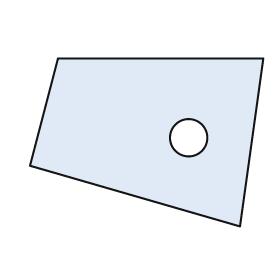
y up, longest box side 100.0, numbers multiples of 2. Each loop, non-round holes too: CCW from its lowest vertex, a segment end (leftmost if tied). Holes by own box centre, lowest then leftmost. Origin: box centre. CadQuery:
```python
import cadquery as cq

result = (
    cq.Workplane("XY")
    .moveTo(40.0, -36.0)
    .lineTo(50.0, 36.0)
    .lineTo(-38.0, 36.0)
    .lineTo(-50.0, -10.0)
    .close()
    .moveTo(18.0, 2.0)
    .circle(8.0)
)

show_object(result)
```